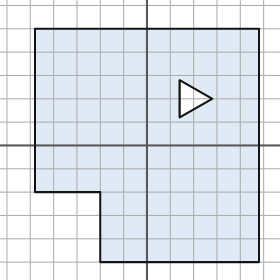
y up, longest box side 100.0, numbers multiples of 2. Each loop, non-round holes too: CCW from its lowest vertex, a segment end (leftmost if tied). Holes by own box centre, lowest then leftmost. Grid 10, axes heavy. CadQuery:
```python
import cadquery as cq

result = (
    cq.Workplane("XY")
    .moveTo(-20.0, -50.0)
    .lineTo(48.0, -50.0)
    .lineTo(48.0, 50.0)
    .lineTo(-48.0, 50.0)
    .lineTo(-48.0, -20.0)
    .lineTo(-20.0, -20.0)
    .close()
    .moveTo(14.0, 12.0)
    .lineTo(28.0, 20.0)
    .lineTo(14.0, 28.0)
    .close()
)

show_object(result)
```